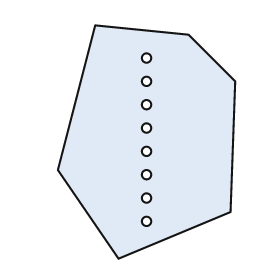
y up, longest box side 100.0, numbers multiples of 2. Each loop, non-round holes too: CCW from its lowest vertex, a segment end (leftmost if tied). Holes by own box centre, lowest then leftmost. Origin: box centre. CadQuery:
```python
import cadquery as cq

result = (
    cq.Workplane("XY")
    .moveTo(-12.0, -50.0)
    .lineTo(36.0, -30.0)
    .lineTo(38.0, 26.0)
    .lineTo(18.0, 46.0)
    .lineTo(-22.0, 50.0)
    .lineTo(-38.0, -12.0)
    .close()
    .moveTo(0.0, -34.0)
    .circle(2.0)
    .moveTo(0.0, -24.0)
    .circle(2.0)
    .moveTo(0.0, -14.0)
    .circle(2.0)
    .moveTo(0.0, -4.0)
    .circle(2.0)
    .moveTo(0.0, 6.0)
    .circle(2.0)
    .moveTo(0.0, 16.0)
    .circle(2.0)
    .moveTo(0.0, 26.0)
    .circle(2.0)
    .moveTo(0.0, 36.0)
    .circle(2.0)
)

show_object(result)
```